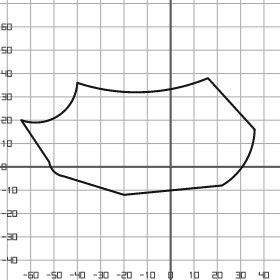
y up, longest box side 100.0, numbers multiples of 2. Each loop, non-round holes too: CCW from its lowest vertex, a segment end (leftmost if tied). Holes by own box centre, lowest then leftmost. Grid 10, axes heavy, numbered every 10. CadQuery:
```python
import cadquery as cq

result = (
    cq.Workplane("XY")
    .moveTo(-20.0, -12.0)
    .lineTo(22.0, -8.0)
    .threePointArc((32.0, 2.0), (36.0, 16.0))
    .lineTo(16.0, 38.0)
    .threePointArc((-12.0, 32.0), (-40.0, 36.0))
    .threePointArc((-48.0, 22.0), (-64.0, 20.0))
    .lineTo(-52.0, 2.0)
    .threePointArc((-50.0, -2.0), (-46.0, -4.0))
    .close()
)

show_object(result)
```